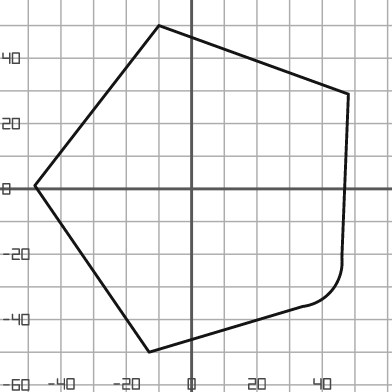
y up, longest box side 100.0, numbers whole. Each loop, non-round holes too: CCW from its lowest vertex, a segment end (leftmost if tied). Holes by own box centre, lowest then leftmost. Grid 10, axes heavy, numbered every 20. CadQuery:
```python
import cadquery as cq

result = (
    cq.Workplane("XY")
    .moveTo(-13.0, -50.0)
    .lineTo(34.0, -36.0)
    .threePointArc((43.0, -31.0), (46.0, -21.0))
    .lineTo(48.0, 29.0)
    .lineTo(-10.0, 50.0)
    .lineTo(-48.0, 1.0)
    .close()
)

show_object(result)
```